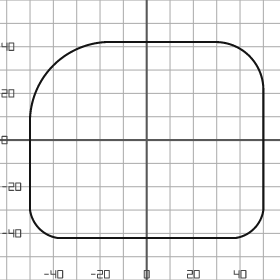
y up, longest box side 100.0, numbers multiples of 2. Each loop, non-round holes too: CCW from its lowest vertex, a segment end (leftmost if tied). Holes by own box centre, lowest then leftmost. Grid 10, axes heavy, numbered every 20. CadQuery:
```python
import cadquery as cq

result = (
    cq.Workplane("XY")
    .moveTo(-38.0, -42.0)
    .lineTo(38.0, -42.0)
    .threePointArc((46.0, -38.0), (50.0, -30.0))
    .lineTo(50.0, 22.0)
    .threePointArc((44.0, 36.0), (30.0, 42.0))
    .lineTo(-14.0, 42.0)
    .threePointArc((-40.0, 32.0), (-50.0, 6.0))
    .lineTo(-50.0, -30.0)
    .threePointArc((-46.0, -38.0), (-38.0, -42.0))
    .close()
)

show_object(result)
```